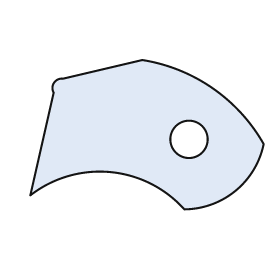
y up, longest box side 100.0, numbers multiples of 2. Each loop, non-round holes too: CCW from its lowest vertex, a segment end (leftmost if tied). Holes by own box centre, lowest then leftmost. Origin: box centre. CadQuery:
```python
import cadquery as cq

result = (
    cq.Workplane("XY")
    .moveTo(16.0, -32.0)
    .threePointArc((38.0, -24.0), (50.0, -4.0))
    .threePointArc((28.0, 20.0), (-2.0, 32.0))
    .lineTo(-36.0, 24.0)
    .threePointArc((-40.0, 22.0), (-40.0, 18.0))
    .lineTo(-50.0, -26.0)
    .threePointArc((-16.0, -16.0), (16.0, -32.0))
    .close()
    .moveTo(18.0, -2.0)
    .circle(8.0)
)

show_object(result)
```